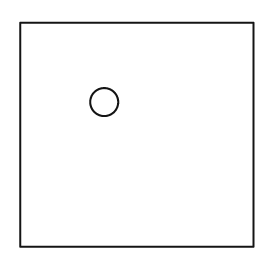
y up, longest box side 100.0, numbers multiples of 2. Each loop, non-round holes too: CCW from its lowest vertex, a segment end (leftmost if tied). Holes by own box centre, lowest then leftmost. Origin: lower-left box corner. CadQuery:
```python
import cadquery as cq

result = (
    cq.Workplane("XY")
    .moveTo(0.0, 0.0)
    .lineTo(100.0, 0.0)
    .lineTo(100.0, 96.0)
    .lineTo(0.0, 96.0)
    .close()
    .moveTo(36.0, 62.0)
    .circle(6.0)
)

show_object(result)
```